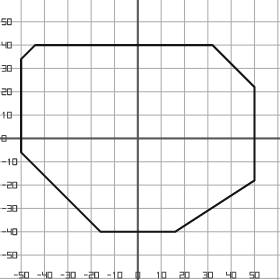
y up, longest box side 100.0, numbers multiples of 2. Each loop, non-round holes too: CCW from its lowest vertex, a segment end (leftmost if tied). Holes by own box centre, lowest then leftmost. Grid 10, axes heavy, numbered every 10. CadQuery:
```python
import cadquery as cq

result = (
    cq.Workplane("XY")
    .moveTo(-16.0, -40.0)
    .lineTo(16.0, -40.0)
    .lineTo(50.0, -18.0)
    .lineTo(50.0, 22.0)
    .lineTo(32.0, 40.0)
    .lineTo(-44.0, 40.0)
    .lineTo(-50.0, 34.0)
    .lineTo(-50.0, -6.0)
    .close()
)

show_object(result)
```